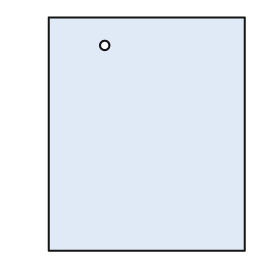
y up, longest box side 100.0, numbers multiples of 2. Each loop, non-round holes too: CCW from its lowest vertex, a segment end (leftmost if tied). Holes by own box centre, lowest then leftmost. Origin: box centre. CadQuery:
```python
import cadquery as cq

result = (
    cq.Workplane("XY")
    .moveTo(-42.0, -50.0)
    .lineTo(42.0, -50.0)
    .lineTo(42.0, 50.0)
    .lineTo(-42.0, 50.0)
    .close()
    .moveTo(-18.0, 38.0)
    .circle(2.0)
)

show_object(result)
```